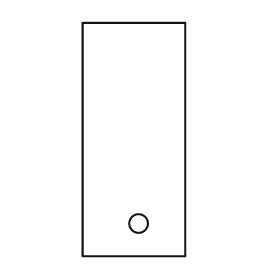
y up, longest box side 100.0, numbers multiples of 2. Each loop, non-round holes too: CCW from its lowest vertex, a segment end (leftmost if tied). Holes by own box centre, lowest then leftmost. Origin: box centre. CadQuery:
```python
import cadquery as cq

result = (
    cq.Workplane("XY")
    .moveTo(-22.0, -50.0)
    .lineTo(22.0, -50.0)
    .lineTo(22.0, 50.0)
    .lineTo(-22.0, 50.0)
    .close()
    .moveTo(2.0, -36.0)
    .circle(4.0)
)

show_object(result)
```